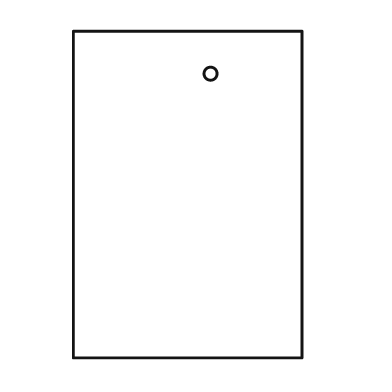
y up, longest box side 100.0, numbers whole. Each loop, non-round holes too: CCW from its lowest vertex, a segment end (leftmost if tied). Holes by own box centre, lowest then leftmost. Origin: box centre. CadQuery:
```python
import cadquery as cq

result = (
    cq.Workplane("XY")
    .moveTo(-35.0, -50.0)
    .lineTo(35.0, -50.0)
    .lineTo(35.0, 50.0)
    .lineTo(-35.0, 50.0)
    .close()
    .moveTo(7.0, 37.0)
    .circle(2.0)
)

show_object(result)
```